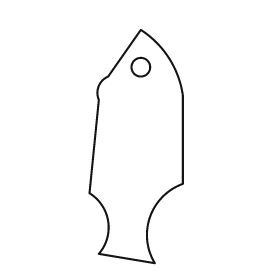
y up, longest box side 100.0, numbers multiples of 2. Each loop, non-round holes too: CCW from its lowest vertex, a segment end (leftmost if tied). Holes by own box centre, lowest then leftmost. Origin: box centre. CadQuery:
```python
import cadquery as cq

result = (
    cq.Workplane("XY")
    .moveTo(8.0, -50.0)
    .threePointArc((6.0, -30.0), (20.0, -16.0))
    .lineTo(20.0, 22.0)
    .threePointArc((14.0, 38.0), (2.0, 50.0))
    .lineTo(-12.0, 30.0)
    .threePointArc((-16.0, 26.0), (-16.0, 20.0))
    .lineTo(-20.0, -20.0)
    .threePointArc((-12.0, -32.0), (-16.0, -46.0))
    .close()
    .moveTo(2.0, 34.0)
    .circle(4.0)
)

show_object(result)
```